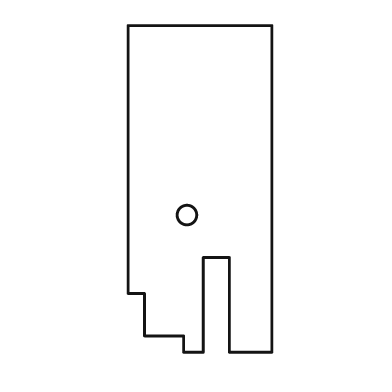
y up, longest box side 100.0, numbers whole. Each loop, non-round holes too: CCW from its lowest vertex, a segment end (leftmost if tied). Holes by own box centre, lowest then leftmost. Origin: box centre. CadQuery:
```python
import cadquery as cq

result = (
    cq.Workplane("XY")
    .moveTo(-5.0, -50.0)
    .lineTo(1.0, -50.0)
    .lineTo(1.0, -21.0)
    .lineTo(9.0, -21.0)
    .lineTo(9.0, -50.0)
    .lineTo(22.0, -50.0)
    .lineTo(22.0, 50.0)
    .lineTo(-22.0, 50.0)
    .lineTo(-22.0, -32.0)
    .lineTo(-17.0, -32.0)
    .lineTo(-17.0, -45.0)
    .lineTo(-5.0, -45.0)
    .close()
    .moveTo(-4.0, -8.0)
    .circle(3.0)
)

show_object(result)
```